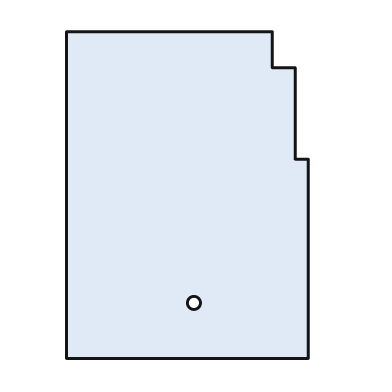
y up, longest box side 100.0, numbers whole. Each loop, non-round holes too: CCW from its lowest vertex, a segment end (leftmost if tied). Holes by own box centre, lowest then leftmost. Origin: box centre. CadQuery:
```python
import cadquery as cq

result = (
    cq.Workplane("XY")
    .moveTo(-37.0, -50.0)
    .lineTo(37.0, -50.0)
    .lineTo(37.0, 11.0)
    .lineTo(33.0, 11.0)
    .lineTo(33.0, 39.0)
    .lineTo(26.0, 39.0)
    .lineTo(26.0, 50.0)
    .lineTo(-37.0, 50.0)
    .close()
    .moveTo(2.0, -33.0)
    .circle(2.0)
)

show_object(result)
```